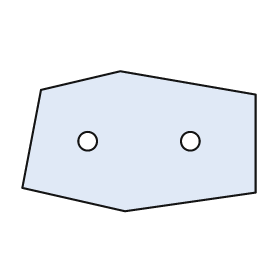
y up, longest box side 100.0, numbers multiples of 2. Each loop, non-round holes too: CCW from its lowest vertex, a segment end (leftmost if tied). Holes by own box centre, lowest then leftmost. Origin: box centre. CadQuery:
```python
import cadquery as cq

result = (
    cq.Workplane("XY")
    .moveTo(-6.0, -30.0)
    .lineTo(50.0, -22.0)
    .lineTo(50.0, 20.0)
    .lineTo(-8.0, 30.0)
    .lineTo(-42.0, 22.0)
    .lineTo(-50.0, -20.0)
    .close()
    .moveTo(-22.0, 0.0)
    .circle(4.0)
    .moveTo(22.0, 0.0)
    .circle(4.0)
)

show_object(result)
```